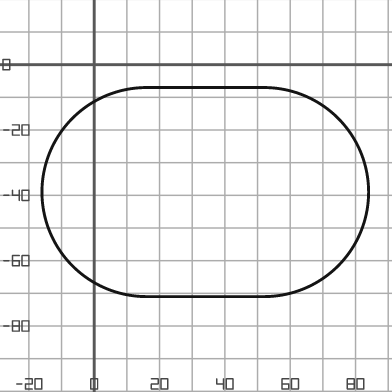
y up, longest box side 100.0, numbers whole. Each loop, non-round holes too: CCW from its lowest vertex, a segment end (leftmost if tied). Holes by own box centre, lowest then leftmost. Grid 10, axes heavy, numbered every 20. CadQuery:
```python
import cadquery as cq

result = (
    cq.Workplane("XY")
    .moveTo(16.0, -71.0)
    .lineTo(52.0, -71.0)
    .threePointArc((84.0, -39.0), (52.0, -7.0))
    .lineTo(16.0, -7.0)
    .threePointArc((-16.0, -39.0), (16.0, -71.0))
    .close()
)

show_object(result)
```